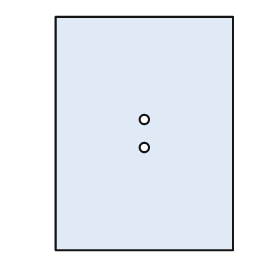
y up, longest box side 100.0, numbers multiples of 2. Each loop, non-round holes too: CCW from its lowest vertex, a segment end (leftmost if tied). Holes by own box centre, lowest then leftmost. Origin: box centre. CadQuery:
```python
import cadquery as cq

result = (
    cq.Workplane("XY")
    .moveTo(-38.0, -50.0)
    .lineTo(38.0, -50.0)
    .lineTo(38.0, 50.0)
    .lineTo(-38.0, 50.0)
    .close()
    .moveTo(0.0, -6.0)
    .circle(2.0)
    .moveTo(0.0, 6.0)
    .circle(2.0)
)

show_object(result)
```